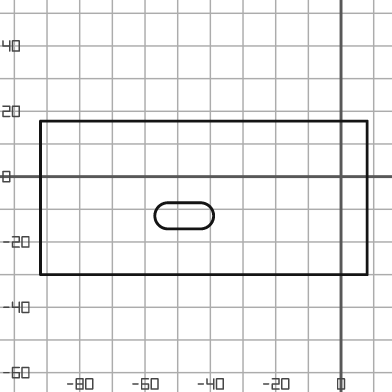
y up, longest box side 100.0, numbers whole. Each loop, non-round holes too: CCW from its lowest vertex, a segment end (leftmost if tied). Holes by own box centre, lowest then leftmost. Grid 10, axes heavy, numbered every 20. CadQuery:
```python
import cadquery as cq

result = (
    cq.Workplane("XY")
    .moveTo(-92.0, -30.0)
    .lineTo(8.0, -30.0)
    .lineTo(8.0, 17.0)
    .lineTo(-92.0, 17.0)
    .close()
    .moveTo(-53.0, -16.0)
    .lineTo(-43.0, -16.0)
    .threePointArc((-39.0, -12.0), (-43.0, -8.0))
    .lineTo(-53.0, -8.0)
    .threePointArc((-57.0, -12.0), (-53.0, -16.0))
    .close()
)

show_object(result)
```